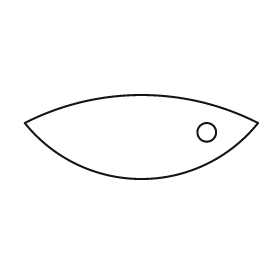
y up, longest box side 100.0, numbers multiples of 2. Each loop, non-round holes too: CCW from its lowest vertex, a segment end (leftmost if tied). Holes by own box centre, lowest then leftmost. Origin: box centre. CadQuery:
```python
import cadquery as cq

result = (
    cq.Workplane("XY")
    .moveTo(-50.0, 6.0)
    .threePointArc((0.0, -18.0), (50.0, 6.0))
    .threePointArc((0.0, 18.0), (-50.0, 6.0))
    .close()
    .moveTo(28.0, 2.0)
    .circle(4.0)
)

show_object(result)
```